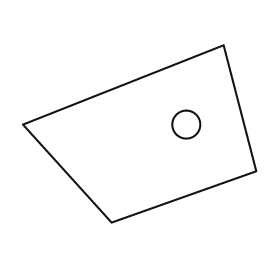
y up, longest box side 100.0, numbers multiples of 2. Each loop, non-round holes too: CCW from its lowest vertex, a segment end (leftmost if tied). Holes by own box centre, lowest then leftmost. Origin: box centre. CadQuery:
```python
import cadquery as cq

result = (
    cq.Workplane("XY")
    .moveTo(-12.0, -38.0)
    .lineTo(50.0, -16.0)
    .lineTo(36.0, 38.0)
    .lineTo(-50.0, 4.0)
    .close()
    .moveTo(20.0, 4.0)
    .circle(6.0)
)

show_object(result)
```